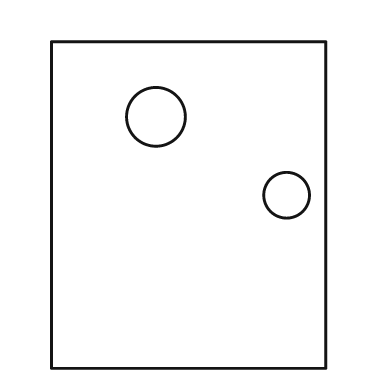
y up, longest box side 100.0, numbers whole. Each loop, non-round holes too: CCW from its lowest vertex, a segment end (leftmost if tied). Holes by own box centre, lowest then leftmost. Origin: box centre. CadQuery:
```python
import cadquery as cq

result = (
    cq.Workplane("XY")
    .moveTo(-42.0, -50.0)
    .lineTo(42.0, -50.0)
    .lineTo(42.0, 50.0)
    .lineTo(-42.0, 50.0)
    .close()
    .moveTo(30.0, 3.0)
    .circle(7.0)
    .moveTo(-10.0, 27.0)
    .circle(9.0)
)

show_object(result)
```